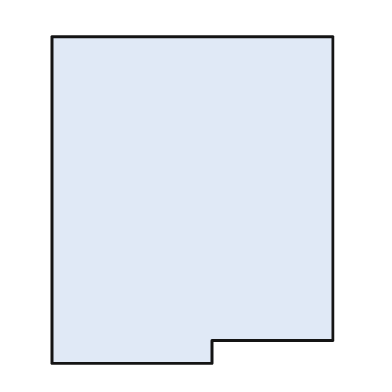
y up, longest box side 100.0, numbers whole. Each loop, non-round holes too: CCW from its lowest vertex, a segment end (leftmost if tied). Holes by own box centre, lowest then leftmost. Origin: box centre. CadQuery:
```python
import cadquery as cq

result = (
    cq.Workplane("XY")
    .moveTo(-43.0, -50.0)
    .lineTo(6.0, -50.0)
    .lineTo(6.0, -43.0)
    .lineTo(43.0, -43.0)
    .lineTo(43.0, 50.0)
    .lineTo(-43.0, 50.0)
    .close()
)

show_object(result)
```